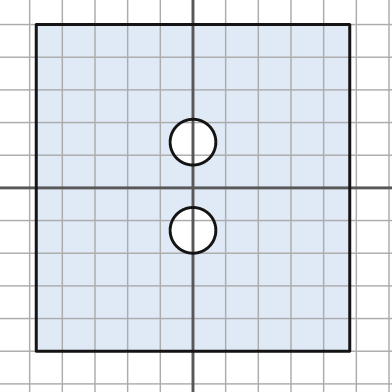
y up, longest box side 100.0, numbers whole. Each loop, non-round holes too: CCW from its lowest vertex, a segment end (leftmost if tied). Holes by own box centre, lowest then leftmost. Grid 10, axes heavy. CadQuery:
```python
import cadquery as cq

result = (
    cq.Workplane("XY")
    .moveTo(-48.0, -50.0)
    .lineTo(48.0, -50.0)
    .lineTo(48.0, 50.0)
    .lineTo(-48.0, 50.0)
    .close()
    .moveTo(0.0, -13.0)
    .circle(7.0)
    .moveTo(0.0, 14.0)
    .circle(7.0)
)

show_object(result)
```